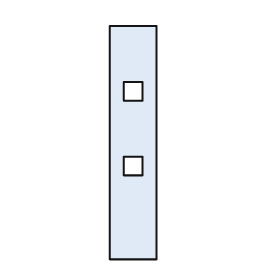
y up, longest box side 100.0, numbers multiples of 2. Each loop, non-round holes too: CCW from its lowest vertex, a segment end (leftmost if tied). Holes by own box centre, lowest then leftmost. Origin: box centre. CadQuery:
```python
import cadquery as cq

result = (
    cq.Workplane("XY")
    .moveTo(-10.0, -50.0)
    .lineTo(10.0, -50.0)
    .lineTo(10.0, 50.0)
    .lineTo(-10.0, 50.0)
    .close()
    .moveTo(-4.0, -14.0)
    .lineTo(4.0, -14.0)
    .lineTo(4.0, -6.0)
    .lineTo(-4.0, -6.0)
    .close()
    .moveTo(-4.0, 18.0)
    .lineTo(4.0, 18.0)
    .lineTo(4.0, 26.0)
    .lineTo(-4.0, 26.0)
    .close()
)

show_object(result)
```